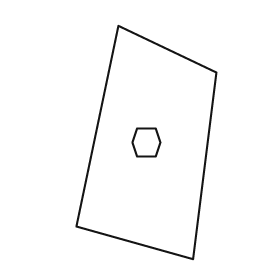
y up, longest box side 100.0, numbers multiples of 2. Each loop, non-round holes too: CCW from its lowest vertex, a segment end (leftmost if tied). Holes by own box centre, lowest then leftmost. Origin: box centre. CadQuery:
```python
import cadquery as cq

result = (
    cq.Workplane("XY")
    .moveTo(20.0, -50.0)
    .lineTo(30.0, 30.0)
    .lineTo(-12.0, 50.0)
    .lineTo(-30.0, -36.0)
    .close()
    .moveTo(-4.0, -6.0)
    .lineTo(4.0, -6.0)
    .lineTo(6.0, 0.0)
    .lineTo(4.0, 6.0)
    .lineTo(-4.0, 6.0)
    .lineTo(-6.0, 0.0)
    .close()
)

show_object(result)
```